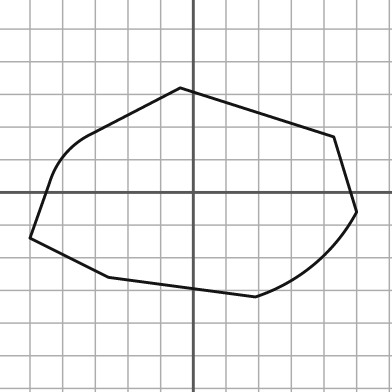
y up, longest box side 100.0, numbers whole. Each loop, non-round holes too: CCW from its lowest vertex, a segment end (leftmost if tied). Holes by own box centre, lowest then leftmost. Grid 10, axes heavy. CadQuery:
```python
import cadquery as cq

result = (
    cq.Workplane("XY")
    .moveTo(19.0, -32.0)
    .threePointArc((37.0, -22.0), (50.0, -6.0))
    .lineTo(43.0, 17.0)
    .lineTo(-4.0, 32.0)
    .lineTo(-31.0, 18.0)
    .threePointArc((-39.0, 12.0), (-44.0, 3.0))
    .lineTo(-50.0, -14.0)
    .lineTo(-26.0, -26.0)
    .close()
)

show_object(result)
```